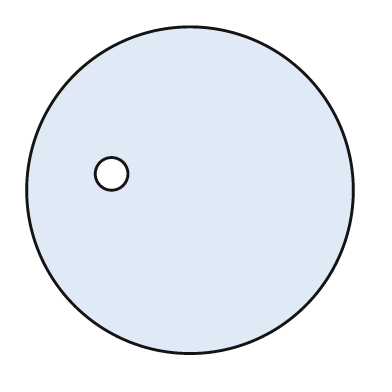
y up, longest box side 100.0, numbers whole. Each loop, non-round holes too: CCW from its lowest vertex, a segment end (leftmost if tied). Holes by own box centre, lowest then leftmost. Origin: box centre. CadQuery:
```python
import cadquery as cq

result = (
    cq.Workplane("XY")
    .moveTo(0.0, 0.0)
    .circle(50.0)
    .moveTo(-24.0, 5.0)
    .circle(5.0)
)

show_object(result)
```